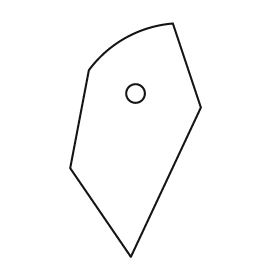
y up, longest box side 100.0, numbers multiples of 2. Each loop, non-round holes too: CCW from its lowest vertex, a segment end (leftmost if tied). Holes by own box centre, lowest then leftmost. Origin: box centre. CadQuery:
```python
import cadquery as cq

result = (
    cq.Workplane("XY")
    .moveTo(-2.0, -50.0)
    .lineTo(28.0, 14.0)
    .lineTo(16.0, 50.0)
    .threePointArc((-4.0, 44.0), (-20.0, 30.0))
    .lineTo(-28.0, -12.0)
    .close()
    .moveTo(0.0, 20.0)
    .circle(4.0)
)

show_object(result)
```